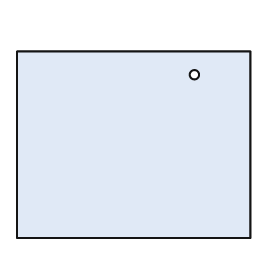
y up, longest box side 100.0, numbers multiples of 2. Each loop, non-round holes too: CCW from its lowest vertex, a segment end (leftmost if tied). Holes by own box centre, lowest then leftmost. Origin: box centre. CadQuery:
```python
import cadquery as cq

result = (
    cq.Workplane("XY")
    .moveTo(-50.0, -40.0)
    .lineTo(50.0, -40.0)
    .lineTo(50.0, 40.0)
    .lineTo(-50.0, 40.0)
    .close()
    .moveTo(26.0, 30.0)
    .circle(2.0)
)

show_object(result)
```